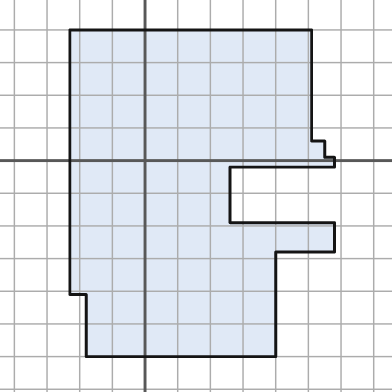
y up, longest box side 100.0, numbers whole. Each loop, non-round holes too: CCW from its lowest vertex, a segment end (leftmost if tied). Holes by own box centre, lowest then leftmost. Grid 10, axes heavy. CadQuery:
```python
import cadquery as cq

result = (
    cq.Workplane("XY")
    .moveTo(-18.0, -60.0)
    .lineTo(40.0, -60.0)
    .lineTo(40.0, -28.0)
    .lineTo(58.0, -28.0)
    .lineTo(58.0, -19.0)
    .lineTo(26.0, -19.0)
    .lineTo(26.0, -2.0)
    .lineTo(58.0, -2.0)
    .lineTo(58.0, 1.0)
    .lineTo(55.0, 1.0)
    .lineTo(55.0, 6.0)
    .lineTo(51.0, 6.0)
    .lineTo(51.0, 40.0)
    .lineTo(-23.0, 40.0)
    .lineTo(-23.0, -41.0)
    .lineTo(-18.0, -41.0)
    .close()
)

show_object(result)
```